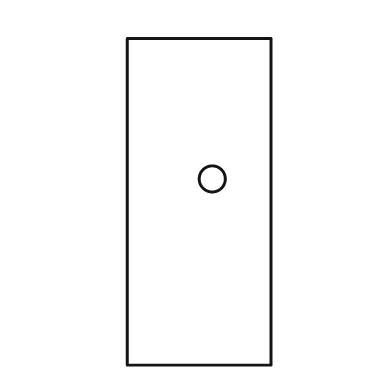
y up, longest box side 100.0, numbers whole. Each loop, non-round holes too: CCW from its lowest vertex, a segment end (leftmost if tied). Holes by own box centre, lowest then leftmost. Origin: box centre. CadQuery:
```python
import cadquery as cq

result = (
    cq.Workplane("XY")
    .moveTo(-22.0, -50.0)
    .lineTo(22.0, -50.0)
    .lineTo(22.0, 50.0)
    .lineTo(-22.0, 50.0)
    .close()
    .moveTo(4.0, 7.0)
    .circle(4.0)
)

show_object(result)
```